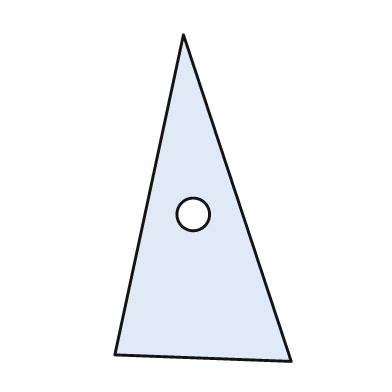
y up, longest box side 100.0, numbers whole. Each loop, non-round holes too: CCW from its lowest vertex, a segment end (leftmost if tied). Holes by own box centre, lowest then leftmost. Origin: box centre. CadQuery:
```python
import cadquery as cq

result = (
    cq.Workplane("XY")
    .moveTo(27.0, -50.0)
    .lineTo(-6.0, 50.0)
    .lineTo(-27.0, -48.0)
    .close()
    .moveTo(-3.0, -5.0)
    .circle(5.0)
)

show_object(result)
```